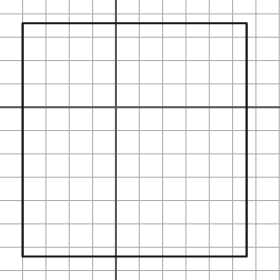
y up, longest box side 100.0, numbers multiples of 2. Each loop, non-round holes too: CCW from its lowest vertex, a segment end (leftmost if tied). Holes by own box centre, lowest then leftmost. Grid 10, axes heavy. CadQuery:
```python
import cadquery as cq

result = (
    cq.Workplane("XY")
    .moveTo(-40.0, -64.0)
    .lineTo(56.0, -64.0)
    .lineTo(56.0, 36.0)
    .lineTo(-40.0, 36.0)
    .close()
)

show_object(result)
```